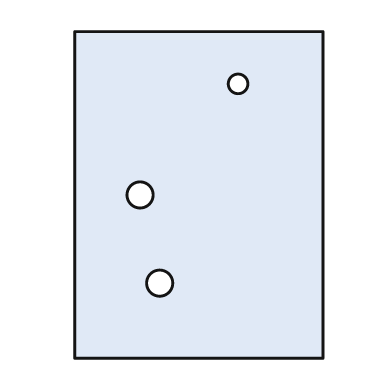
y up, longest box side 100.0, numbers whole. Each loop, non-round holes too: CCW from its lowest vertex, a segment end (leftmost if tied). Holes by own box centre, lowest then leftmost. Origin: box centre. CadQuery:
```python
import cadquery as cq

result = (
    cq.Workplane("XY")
    .moveTo(-38.0, -50.0)
    .lineTo(38.0, -50.0)
    .lineTo(38.0, 50.0)
    .lineTo(-38.0, 50.0)
    .close()
    .moveTo(-12.0, -27.0)
    .circle(4.0)
    .moveTo(-18.0, 0.0)
    .circle(4.0)
    .moveTo(12.0, 34.0)
    .circle(3.0)
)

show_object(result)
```